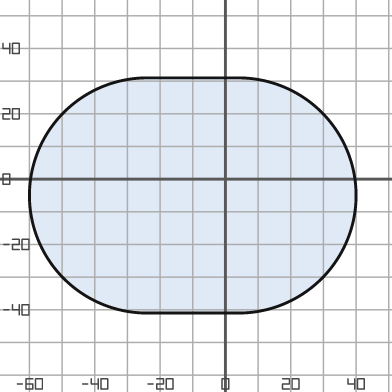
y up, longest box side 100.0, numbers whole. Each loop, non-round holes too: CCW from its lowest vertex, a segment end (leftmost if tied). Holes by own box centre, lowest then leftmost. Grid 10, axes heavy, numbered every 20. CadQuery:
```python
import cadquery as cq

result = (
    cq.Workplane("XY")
    .moveTo(-24.0, -41.0)
    .lineTo(4.0, -41.0)
    .threePointArc((40.0, -5.0), (4.0, 31.0))
    .lineTo(-24.0, 31.0)
    .threePointArc((-60.0, -5.0), (-24.0, -41.0))
    .close()
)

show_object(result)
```